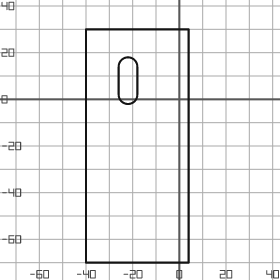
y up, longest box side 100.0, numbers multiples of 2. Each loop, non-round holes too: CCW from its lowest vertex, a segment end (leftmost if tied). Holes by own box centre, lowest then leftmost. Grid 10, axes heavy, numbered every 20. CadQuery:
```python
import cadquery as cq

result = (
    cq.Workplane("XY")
    .moveTo(-40.0, -70.0)
    .lineTo(4.0, -70.0)
    .lineTo(4.0, 30.0)
    .lineTo(-40.0, 30.0)
    .close()
    .moveTo(-26.0, 2.0)
    .threePointArc((-22.0, -2.0), (-18.0, 2.0))
    .lineTo(-18.0, 14.0)
    .threePointArc((-22.0, 18.0), (-26.0, 14.0))
    .close()
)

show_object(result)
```